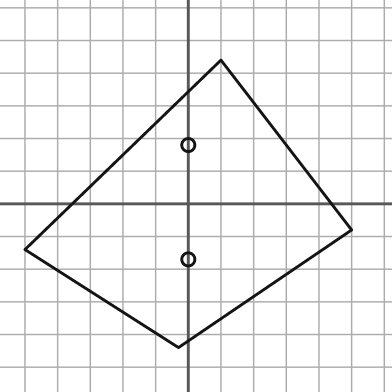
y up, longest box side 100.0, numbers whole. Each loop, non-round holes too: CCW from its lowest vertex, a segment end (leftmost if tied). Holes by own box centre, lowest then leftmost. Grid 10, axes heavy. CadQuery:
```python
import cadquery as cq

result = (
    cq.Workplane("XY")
    .moveTo(-3.0, -44.0)
    .lineTo(50.0, -8.0)
    .lineTo(10.0, 44.0)
    .lineTo(-50.0, -14.0)
    .close()
    .moveTo(0.0, -17.0)
    .circle(2.0)
    .moveTo(0.0, 18.0)
    .circle(2.0)
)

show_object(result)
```